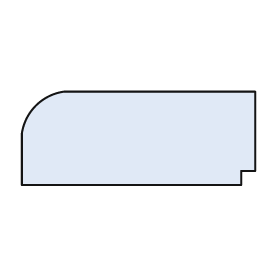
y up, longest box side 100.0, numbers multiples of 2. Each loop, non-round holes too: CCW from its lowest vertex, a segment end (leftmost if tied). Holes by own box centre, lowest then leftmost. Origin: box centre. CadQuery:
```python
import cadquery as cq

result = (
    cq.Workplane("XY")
    .moveTo(-50.0, -20.0)
    .lineTo(44.0, -20.0)
    .lineTo(44.0, -14.0)
    .lineTo(50.0, -14.0)
    .lineTo(50.0, 20.0)
    .lineTo(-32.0, 20.0)
    .threePointArc((-44.0, 14.0), (-50.0, 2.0))
    .close()
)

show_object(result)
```